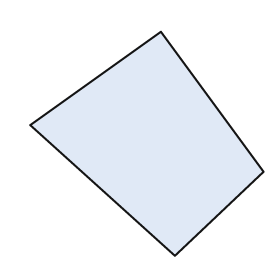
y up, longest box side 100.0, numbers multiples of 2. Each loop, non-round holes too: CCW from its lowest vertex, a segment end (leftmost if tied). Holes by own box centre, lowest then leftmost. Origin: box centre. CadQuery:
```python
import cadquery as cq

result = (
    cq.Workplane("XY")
    .moveTo(12.0, -48.0)
    .lineTo(50.0, -12.0)
    .lineTo(6.0, 48.0)
    .lineTo(-50.0, 8.0)
    .close()
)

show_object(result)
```